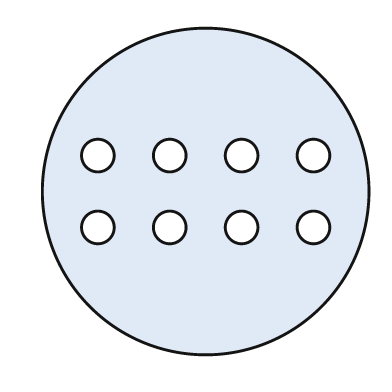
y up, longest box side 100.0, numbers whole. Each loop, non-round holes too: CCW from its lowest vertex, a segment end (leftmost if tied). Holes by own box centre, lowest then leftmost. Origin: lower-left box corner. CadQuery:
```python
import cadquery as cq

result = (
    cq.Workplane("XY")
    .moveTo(50.0, 50.0)
    .circle(50.0)
    .moveTo(17.0, 39.0)
    .circle(5.0)
    .moveTo(39.0, 39.0)
    .circle(5.0)
    .moveTo(61.0, 39.0)
    .circle(5.0)
    .moveTo(83.0, 39.0)
    .circle(5.0)
    .moveTo(17.0, 61.0)
    .circle(5.0)
    .moveTo(39.0, 61.0)
    .circle(5.0)
    .moveTo(61.0, 61.0)
    .circle(5.0)
    .moveTo(83.0, 61.0)
    .circle(5.0)
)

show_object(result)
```